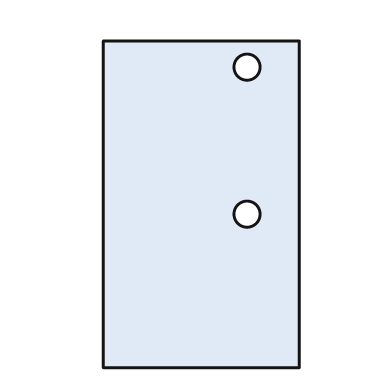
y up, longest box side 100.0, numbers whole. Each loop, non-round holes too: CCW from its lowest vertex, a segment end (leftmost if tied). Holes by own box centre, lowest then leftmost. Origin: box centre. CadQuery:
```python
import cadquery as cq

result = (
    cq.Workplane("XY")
    .moveTo(-30.0, -50.0)
    .lineTo(30.0, -50.0)
    .lineTo(30.0, 50.0)
    .lineTo(-30.0, 50.0)
    .close()
    .moveTo(14.0, -3.0)
    .circle(4.0)
    .moveTo(14.0, 42.0)
    .circle(4.0)
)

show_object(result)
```